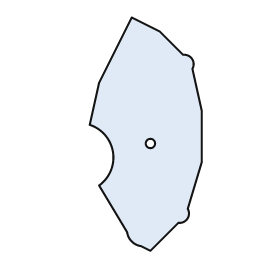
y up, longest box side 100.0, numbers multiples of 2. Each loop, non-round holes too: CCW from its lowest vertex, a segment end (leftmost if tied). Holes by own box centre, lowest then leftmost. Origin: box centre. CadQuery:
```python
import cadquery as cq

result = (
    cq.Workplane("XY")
    .moveTo(2.0, -50.0)
    .lineTo(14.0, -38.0)
    .threePointArc((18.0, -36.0), (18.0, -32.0))
    .lineTo(24.0, -12.0)
    .lineTo(24.0, 10.0)
    .lineTo(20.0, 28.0)
    .threePointArc((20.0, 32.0), (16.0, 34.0))
    .lineTo(6.0, 44.0)
    .lineTo(-6.0, 50.0)
    .lineTo(-20.0, 22.0)
    .lineTo(-24.0, 4.0)
    .threePointArc((-14.0, -8.0), (-20.0, -22.0))
    .lineTo(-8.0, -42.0)
    .threePointArc((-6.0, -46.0), (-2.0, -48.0))
    .close()
    .moveTo(2.0, -4.0)
    .circle(2.0)
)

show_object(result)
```